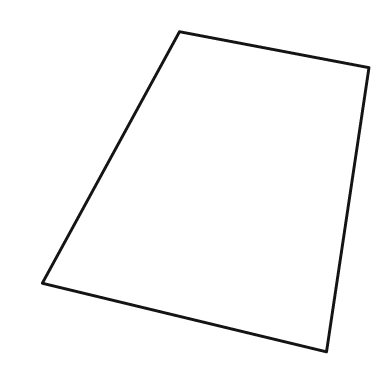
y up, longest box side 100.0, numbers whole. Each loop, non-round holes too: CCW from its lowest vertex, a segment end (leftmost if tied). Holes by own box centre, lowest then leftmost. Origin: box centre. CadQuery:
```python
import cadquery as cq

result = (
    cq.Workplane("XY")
    .moveTo(37.0, -49.0)
    .lineTo(50.0, 38.0)
    .lineTo(-8.0, 49.0)
    .lineTo(-50.0, -28.0)
    .close()
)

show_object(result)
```